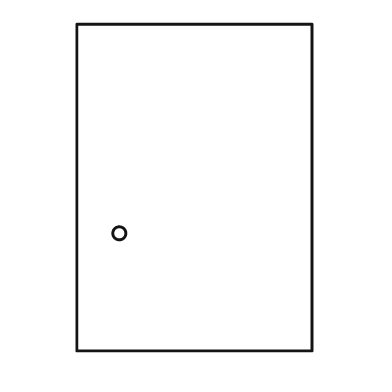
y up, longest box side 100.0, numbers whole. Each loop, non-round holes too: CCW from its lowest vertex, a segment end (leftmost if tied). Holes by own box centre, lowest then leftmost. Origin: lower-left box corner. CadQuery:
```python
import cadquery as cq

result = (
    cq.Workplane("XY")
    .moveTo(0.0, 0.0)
    .lineTo(72.0, 0.0)
    .lineTo(72.0, 100.0)
    .lineTo(0.0, 100.0)
    .close()
    .moveTo(13.0, 36.0)
    .circle(2.0)
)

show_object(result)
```